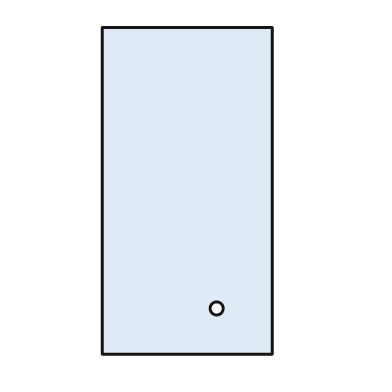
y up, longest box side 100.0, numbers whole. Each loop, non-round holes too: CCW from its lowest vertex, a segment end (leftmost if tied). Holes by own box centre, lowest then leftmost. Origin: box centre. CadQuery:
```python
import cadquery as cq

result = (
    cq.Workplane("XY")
    .moveTo(-26.0, -50.0)
    .lineTo(26.0, -50.0)
    .lineTo(26.0, 50.0)
    .lineTo(-26.0, 50.0)
    .close()
    .moveTo(9.0, -36.0)
    .circle(2.0)
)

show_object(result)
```